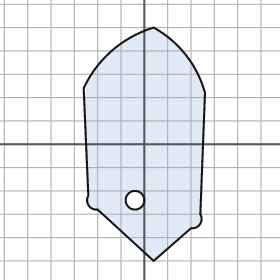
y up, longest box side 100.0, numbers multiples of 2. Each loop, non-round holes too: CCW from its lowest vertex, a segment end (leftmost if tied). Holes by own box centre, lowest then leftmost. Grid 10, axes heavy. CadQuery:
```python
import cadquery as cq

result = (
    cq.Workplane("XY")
    .moveTo(4.0, -50.0)
    .lineTo(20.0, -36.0)
    .threePointArc((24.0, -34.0), (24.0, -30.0))
    .lineTo(26.0, 22.0)
    .threePointArc((18.0, 38.0), (4.0, 50.0))
    .threePointArc((-14.0, 40.0), (-26.0, 24.0))
    .lineTo(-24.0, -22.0)
    .threePointArc((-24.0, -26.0), (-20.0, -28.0))
    .close()
    .moveTo(-4.0, -24.0)
    .circle(4.0)
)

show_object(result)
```